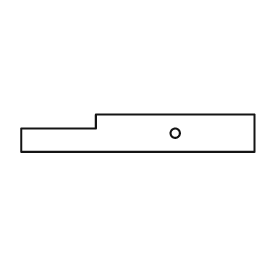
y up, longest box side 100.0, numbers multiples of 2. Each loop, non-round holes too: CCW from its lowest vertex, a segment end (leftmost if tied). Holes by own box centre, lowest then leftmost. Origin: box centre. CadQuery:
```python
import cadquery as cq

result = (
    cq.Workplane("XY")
    .moveTo(-50.0, -8.0)
    .lineTo(50.0, -8.0)
    .lineTo(50.0, 8.0)
    .lineTo(-18.0, 8.0)
    .lineTo(-18.0, 2.0)
    .lineTo(-50.0, 2.0)
    .close()
    .moveTo(16.0, 0.0)
    .circle(2.0)
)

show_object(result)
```